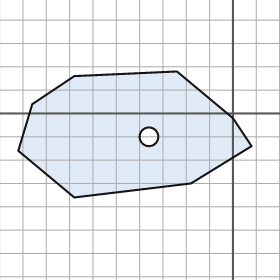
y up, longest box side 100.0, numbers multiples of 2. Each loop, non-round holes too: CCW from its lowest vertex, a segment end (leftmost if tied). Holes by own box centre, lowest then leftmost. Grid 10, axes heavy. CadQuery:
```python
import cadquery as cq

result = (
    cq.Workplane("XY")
    .moveTo(-68.0, -36.0)
    .lineTo(-18.0, -30.0)
    .lineTo(8.0, -14.0)
    .lineTo(0.0, -2.0)
    .lineTo(-24.0, 18.0)
    .lineTo(-68.0, 16.0)
    .lineTo(-86.0, 4.0)
    .lineTo(-92.0, -16.0)
    .close()
    .moveTo(-36.0, -10.0)
    .circle(4.0)
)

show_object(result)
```